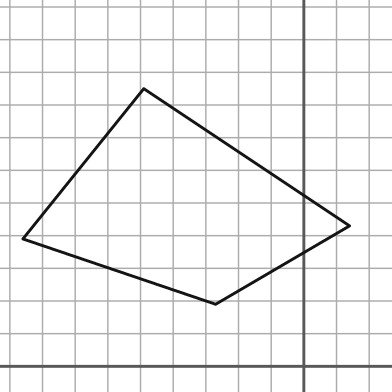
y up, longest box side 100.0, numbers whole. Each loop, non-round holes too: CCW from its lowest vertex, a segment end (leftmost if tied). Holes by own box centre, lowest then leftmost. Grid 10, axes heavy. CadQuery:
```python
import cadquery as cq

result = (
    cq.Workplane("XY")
    .moveTo(-27.0, 19.0)
    .lineTo(14.0, 43.0)
    .lineTo(-49.0, 85.0)
    .lineTo(-86.0, 39.0)
    .close()
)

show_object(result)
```